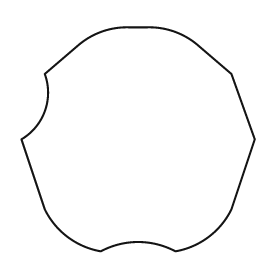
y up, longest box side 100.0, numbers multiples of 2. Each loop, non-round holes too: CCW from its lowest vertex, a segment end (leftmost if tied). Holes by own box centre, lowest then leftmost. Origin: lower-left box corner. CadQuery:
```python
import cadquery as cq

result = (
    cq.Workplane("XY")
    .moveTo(34.0, 0.0)
    .threePointArc((50.0, 4.0), (66.0, 0.0))
    .threePointArc((80.0, 6.0), (90.0, 18.0))
    .lineTo(100.0, 48.0)
    .lineTo(90.0, 76.0)
    .lineTo(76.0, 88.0)
    .threePointArc((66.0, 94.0), (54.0, 96.0))
    .lineTo(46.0, 96.0)
    .threePointArc((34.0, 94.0), (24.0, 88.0))
    .lineTo(10.0, 76.0)
    .threePointArc((10.0, 60.0), (0.0, 48.0))
    .lineTo(10.0, 18.0)
    .threePointArc((20.0, 6.0), (34.0, 0.0))
    .close()
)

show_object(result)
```